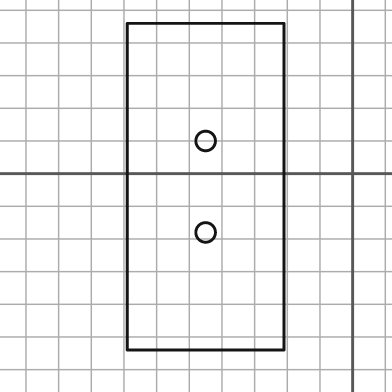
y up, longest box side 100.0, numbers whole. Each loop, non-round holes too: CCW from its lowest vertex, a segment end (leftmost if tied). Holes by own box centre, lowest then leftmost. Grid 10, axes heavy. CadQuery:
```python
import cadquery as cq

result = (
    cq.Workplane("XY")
    .moveTo(-69.0, -54.0)
    .lineTo(-21.0, -54.0)
    .lineTo(-21.0, 46.0)
    .lineTo(-69.0, 46.0)
    .close()
    .moveTo(-45.0, -18.0)
    .circle(3.0)
    .moveTo(-45.0, 10.0)
    .circle(3.0)
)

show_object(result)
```